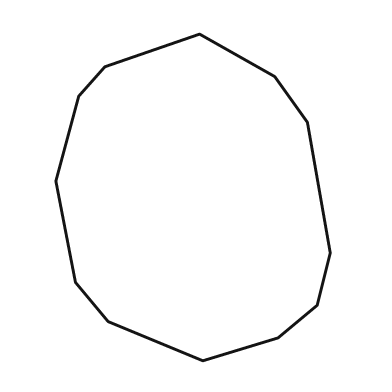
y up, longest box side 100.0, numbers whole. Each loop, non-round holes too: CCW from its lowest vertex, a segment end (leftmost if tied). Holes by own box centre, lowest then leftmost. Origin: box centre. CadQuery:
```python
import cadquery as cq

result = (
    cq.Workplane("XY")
    .moveTo(3.0, -50.0)
    .lineTo(26.0, -43.0)
    .lineTo(38.0, -33.0)
    .lineTo(42.0, -17.0)
    .lineTo(35.0, 23.0)
    .lineTo(25.0, 37.0)
    .lineTo(2.0, 50.0)
    .lineTo(-27.0, 40.0)
    .lineTo(-35.0, 31.0)
    .lineTo(-42.0, 5.0)
    .lineTo(-36.0, -26.0)
    .lineTo(-26.0, -38.0)
    .close()
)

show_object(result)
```